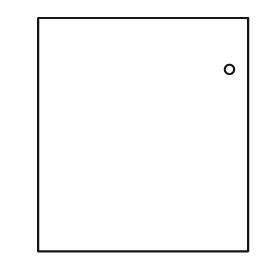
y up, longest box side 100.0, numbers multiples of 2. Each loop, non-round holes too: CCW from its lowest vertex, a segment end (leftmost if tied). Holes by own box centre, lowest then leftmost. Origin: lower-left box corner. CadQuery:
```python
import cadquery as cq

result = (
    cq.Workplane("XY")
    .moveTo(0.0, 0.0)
    .lineTo(90.0, 0.0)
    .lineTo(90.0, 100.0)
    .lineTo(0.0, 100.0)
    .close()
    .moveTo(82.0, 78.0)
    .circle(2.0)
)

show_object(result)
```